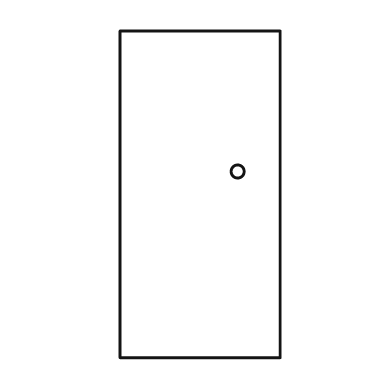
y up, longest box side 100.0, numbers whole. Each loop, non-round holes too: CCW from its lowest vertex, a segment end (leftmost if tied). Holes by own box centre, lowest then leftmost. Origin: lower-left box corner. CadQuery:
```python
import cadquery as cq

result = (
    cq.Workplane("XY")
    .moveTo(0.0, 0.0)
    .lineTo(49.0, 0.0)
    .lineTo(49.0, 100.0)
    .lineTo(0.0, 100.0)
    .close()
    .moveTo(36.0, 57.0)
    .circle(2.0)
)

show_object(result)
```